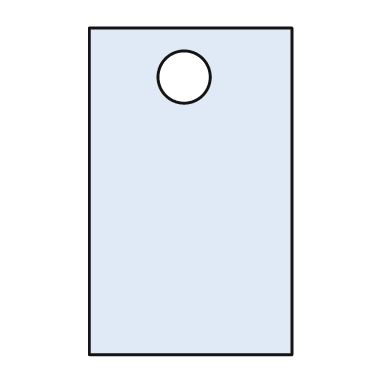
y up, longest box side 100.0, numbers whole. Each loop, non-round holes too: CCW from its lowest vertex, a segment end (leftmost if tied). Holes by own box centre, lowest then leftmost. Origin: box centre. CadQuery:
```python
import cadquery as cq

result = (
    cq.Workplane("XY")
    .moveTo(-31.0, -50.0)
    .lineTo(31.0, -50.0)
    .lineTo(31.0, 50.0)
    .lineTo(-31.0, 50.0)
    .close()
    .moveTo(-2.0, 35.0)
    .circle(8.0)
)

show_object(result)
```